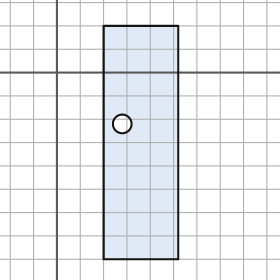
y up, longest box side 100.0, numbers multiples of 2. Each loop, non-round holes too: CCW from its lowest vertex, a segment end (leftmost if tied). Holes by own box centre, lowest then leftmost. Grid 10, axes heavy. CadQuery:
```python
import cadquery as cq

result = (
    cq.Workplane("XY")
    .moveTo(20.0, -80.0)
    .lineTo(52.0, -80.0)
    .lineTo(52.0, 20.0)
    .lineTo(20.0, 20.0)
    .close()
    .moveTo(28.0, -22.0)
    .circle(4.0)
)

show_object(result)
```